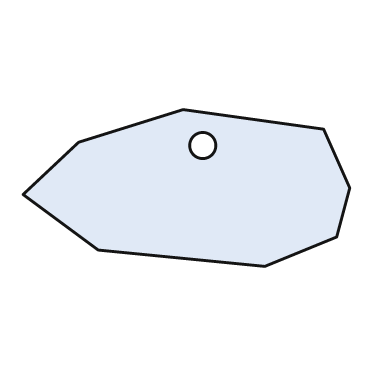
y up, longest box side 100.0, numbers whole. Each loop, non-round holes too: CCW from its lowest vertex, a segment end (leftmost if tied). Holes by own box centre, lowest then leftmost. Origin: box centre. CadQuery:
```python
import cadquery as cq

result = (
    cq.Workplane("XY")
    .moveTo(24.0, -24.0)
    .lineTo(46.0, -15.0)
    .lineTo(50.0, 0.0)
    .lineTo(42.0, 18.0)
    .lineTo(-1.0, 24.0)
    .lineTo(-33.0, 14.0)
    .lineTo(-50.0, -2.0)
    .lineTo(-27.0, -19.0)
    .close()
    .moveTo(5.0, 13.0)
    .circle(4.0)
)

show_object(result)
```